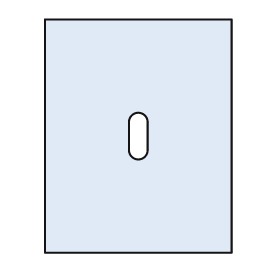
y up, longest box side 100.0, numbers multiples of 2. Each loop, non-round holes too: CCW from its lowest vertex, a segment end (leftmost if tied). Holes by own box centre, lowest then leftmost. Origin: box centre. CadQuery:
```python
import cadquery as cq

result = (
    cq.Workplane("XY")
    .moveTo(-40.0, -50.0)
    .lineTo(40.0, -50.0)
    .lineTo(40.0, 50.0)
    .lineTo(-40.0, 50.0)
    .close()
    .moveTo(-4.0, -6.0)
    .threePointArc((0.0, -10.0), (4.0, -6.0))
    .lineTo(4.0, 6.0)
    .threePointArc((0.0, 10.0), (-4.0, 6.0))
    .close()
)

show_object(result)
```